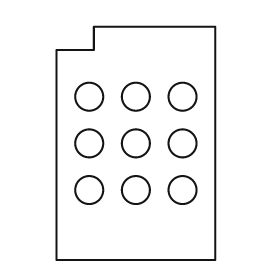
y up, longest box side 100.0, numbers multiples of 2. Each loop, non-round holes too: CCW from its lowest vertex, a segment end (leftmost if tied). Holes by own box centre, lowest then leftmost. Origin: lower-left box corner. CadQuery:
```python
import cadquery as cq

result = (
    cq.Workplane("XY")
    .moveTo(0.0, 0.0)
    .lineTo(68.0, 0.0)
    .lineTo(68.0, 100.0)
    .lineTo(16.0, 100.0)
    .lineTo(16.0, 90.0)
    .lineTo(0.0, 90.0)
    .close()
    .moveTo(14.0, 30.0)
    .circle(6.0)
    .moveTo(34.0, 30.0)
    .circle(6.0)
    .moveTo(54.0, 30.0)
    .circle(6.0)
    .moveTo(14.0, 50.0)
    .circle(6.0)
    .moveTo(34.0, 50.0)
    .circle(6.0)
    .moveTo(54.0, 50.0)
    .circle(6.0)
    .moveTo(14.0, 70.0)
    .circle(6.0)
    .moveTo(34.0, 70.0)
    .circle(6.0)
    .moveTo(54.0, 70.0)
    .circle(6.0)
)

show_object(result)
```